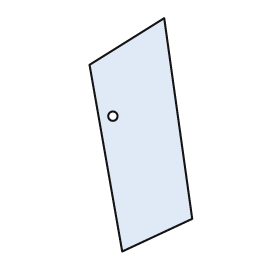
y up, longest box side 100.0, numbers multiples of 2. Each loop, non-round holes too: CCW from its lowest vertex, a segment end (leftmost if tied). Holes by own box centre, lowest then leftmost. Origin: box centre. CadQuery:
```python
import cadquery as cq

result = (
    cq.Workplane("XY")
    .moveTo(-8.0, -50.0)
    .lineTo(22.0, -36.0)
    .lineTo(10.0, 50.0)
    .lineTo(-22.0, 30.0)
    .close()
    .moveTo(-12.0, 8.0)
    .circle(2.0)
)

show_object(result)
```